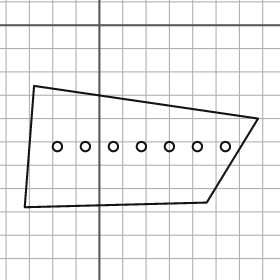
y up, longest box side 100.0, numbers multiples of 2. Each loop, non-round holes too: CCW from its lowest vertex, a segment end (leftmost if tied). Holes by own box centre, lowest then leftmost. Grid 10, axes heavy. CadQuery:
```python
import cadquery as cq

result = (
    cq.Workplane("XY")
    .moveTo(-32.0, -78.0)
    .lineTo(46.0, -76.0)
    .lineTo(68.0, -40.0)
    .lineTo(-28.0, -26.0)
    .close()
    .moveTo(-18.0, -52.0)
    .circle(2.0)
    .moveTo(-6.0, -52.0)
    .circle(2.0)
    .moveTo(6.0, -52.0)
    .circle(2.0)
    .moveTo(18.0, -52.0)
    .circle(2.0)
    .moveTo(30.0, -52.0)
    .circle(2.0)
    .moveTo(42.0, -52.0)
    .circle(2.0)
    .moveTo(54.0, -52.0)
    .circle(2.0)
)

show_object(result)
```